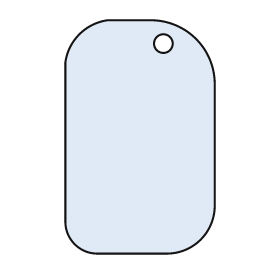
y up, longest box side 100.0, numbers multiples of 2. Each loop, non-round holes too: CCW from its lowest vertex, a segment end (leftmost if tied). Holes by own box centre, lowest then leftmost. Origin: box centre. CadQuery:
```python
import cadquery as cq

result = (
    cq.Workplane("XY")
    .moveTo(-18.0, -50.0)
    .lineTo(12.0, -50.0)
    .threePointArc((26.0, -44.0), (32.0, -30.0))
    .lineTo(32.0, 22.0)
    .threePointArc((24.0, 42.0), (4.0, 50.0))
    .lineTo(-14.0, 50.0)
    .threePointArc((-26.0, 44.0), (-32.0, 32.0))
    .lineTo(-32.0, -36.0)
    .threePointArc((-28.0, -46.0), (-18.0, -50.0))
    .close()
    .moveTo(10.0, 40.0)
    .circle(4.0)
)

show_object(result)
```